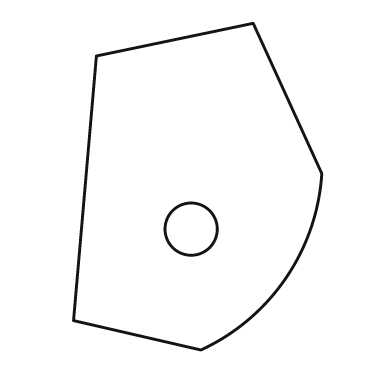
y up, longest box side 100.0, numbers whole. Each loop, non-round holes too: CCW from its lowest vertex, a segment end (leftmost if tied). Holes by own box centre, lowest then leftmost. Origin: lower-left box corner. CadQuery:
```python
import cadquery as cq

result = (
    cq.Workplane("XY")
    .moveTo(39.0, 0.0)
    .threePointArc((65.0, 22.0), (76.0, 54.0))
    .lineTo(55.0, 100.0)
    .lineTo(7.0, 90.0)
    .lineTo(0.0, 9.0)
    .close()
    .moveTo(36.0, 37.0)
    .circle(8.0)
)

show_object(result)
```